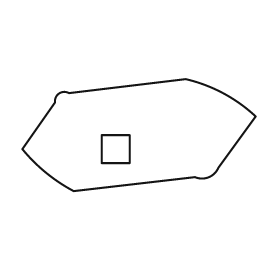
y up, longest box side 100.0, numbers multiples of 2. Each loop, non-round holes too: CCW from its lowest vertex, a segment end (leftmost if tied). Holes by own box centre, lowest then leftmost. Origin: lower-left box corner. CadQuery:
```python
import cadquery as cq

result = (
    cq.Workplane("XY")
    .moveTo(22.0, 0.0)
    .lineTo(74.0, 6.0)
    .threePointArc((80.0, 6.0), (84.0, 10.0))
    .lineTo(100.0, 32.0)
    .threePointArc((86.0, 42.0), (70.0, 48.0))
    .lineTo(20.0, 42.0)
    .threePointArc((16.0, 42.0), (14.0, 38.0))
    .lineTo(0.0, 18.0)
    .threePointArc((10.0, 8.0), (22.0, 0.0))
    .close()
    .moveTo(34.0, 12.0)
    .lineTo(46.0, 12.0)
    .lineTo(46.0, 24.0)
    .lineTo(34.0, 24.0)
    .close()
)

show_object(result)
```